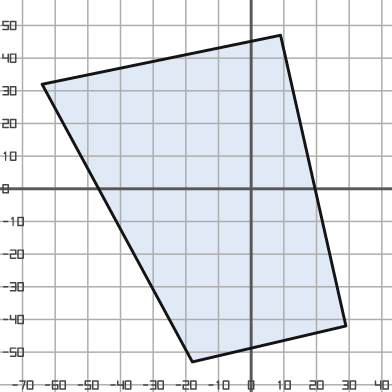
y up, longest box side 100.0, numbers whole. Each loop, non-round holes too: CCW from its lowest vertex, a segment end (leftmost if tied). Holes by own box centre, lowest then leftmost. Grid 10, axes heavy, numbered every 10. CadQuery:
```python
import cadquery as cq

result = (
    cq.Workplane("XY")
    .moveTo(-18.0, -53.0)
    .lineTo(29.0, -42.0)
    .lineTo(9.0, 47.0)
    .lineTo(-64.0, 32.0)
    .close()
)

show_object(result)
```